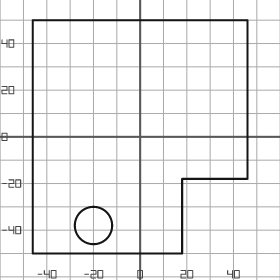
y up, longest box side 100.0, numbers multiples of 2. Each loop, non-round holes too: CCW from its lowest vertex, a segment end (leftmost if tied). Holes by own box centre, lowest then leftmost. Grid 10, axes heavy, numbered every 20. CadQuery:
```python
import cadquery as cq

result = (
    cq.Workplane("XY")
    .moveTo(-46.0, -50.0)
    .lineTo(18.0, -50.0)
    .lineTo(18.0, -18.0)
    .lineTo(46.0, -18.0)
    .lineTo(46.0, 50.0)
    .lineTo(-46.0, 50.0)
    .close()
    .moveTo(-20.0, -38.0)
    .circle(8.0)
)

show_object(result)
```